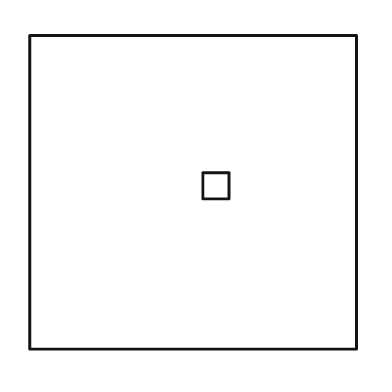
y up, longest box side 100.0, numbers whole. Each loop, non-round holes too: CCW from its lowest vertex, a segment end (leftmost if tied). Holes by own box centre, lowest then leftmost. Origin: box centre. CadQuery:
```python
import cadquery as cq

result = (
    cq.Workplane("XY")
    .moveTo(-50.0, -48.0)
    .lineTo(50.0, -48.0)
    .lineTo(50.0, 48.0)
    .lineTo(-50.0, 48.0)
    .close()
    .moveTo(3.0, -2.0)
    .lineTo(11.0, -2.0)
    .lineTo(11.0, 6.0)
    .lineTo(3.0, 6.0)
    .close()
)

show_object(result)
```